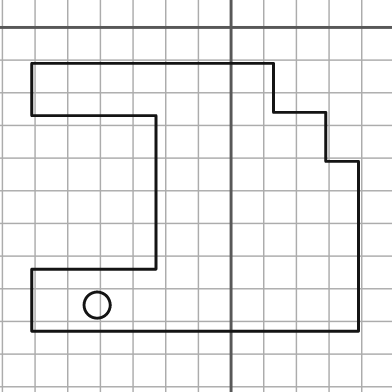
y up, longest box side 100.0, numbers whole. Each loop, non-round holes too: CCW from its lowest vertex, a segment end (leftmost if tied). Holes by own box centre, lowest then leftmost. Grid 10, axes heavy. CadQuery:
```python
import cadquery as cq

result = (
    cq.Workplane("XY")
    .moveTo(-61.0, -93.0)
    .lineTo(39.0, -93.0)
    .lineTo(39.0, -41.0)
    .lineTo(29.0, -41.0)
    .lineTo(29.0, -26.0)
    .lineTo(13.0, -26.0)
    .lineTo(13.0, -11.0)
    .lineTo(-61.0, -11.0)
    .lineTo(-61.0, -27.0)
    .lineTo(-23.0, -27.0)
    .lineTo(-23.0, -74.0)
    .lineTo(-61.0, -74.0)
    .close()
    .moveTo(-41.0, -85.0)
    .circle(4.0)
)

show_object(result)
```